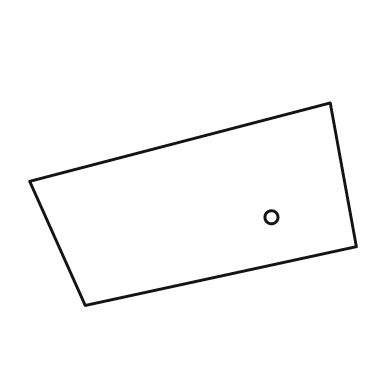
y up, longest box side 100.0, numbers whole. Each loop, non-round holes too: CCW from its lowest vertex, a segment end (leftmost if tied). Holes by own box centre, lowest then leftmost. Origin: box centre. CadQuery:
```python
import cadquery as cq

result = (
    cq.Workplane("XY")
    .moveTo(-33.0, -31.0)
    .lineTo(50.0, -13.0)
    .lineTo(42.0, 31.0)
    .lineTo(-50.0, 7.0)
    .close()
    .moveTo(24.0, -4.0)
    .circle(2.0)
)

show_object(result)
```